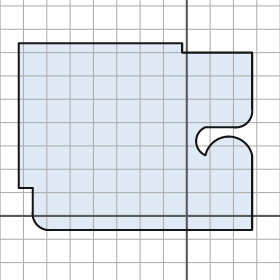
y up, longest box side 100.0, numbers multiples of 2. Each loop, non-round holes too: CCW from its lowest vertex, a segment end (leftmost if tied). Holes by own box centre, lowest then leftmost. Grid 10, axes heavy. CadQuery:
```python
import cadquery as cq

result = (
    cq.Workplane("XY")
    .moveTo(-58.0, -6.0)
    .lineTo(28.0, -6.0)
    .lineTo(28.0, 26.0)
    .threePointArc((18.0, 34.0), (8.0, 26.0))
    .threePointArc((4.0, 32.0), (8.0, 38.0))
    .lineTo(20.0, 38.0)
    .threePointArc((26.0, 40.0), (28.0, 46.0))
    .lineTo(28.0, 70.0)
    .lineTo(-2.0, 70.0)
    .lineTo(-2.0, 74.0)
    .lineTo(-72.0, 74.0)
    .lineTo(-72.0, 12.0)
    .lineTo(-66.0, 12.0)
    .lineTo(-66.0, 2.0)
    .threePointArc((-64.0, -4.0), (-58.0, -6.0))
    .close()
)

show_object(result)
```